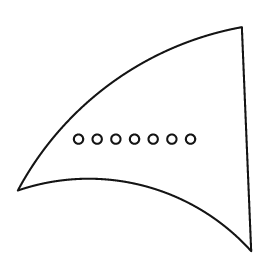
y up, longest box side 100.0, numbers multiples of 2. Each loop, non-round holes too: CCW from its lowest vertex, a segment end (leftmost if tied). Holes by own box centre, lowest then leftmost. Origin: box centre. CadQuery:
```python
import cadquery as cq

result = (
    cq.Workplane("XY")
    .moveTo(50.0, -48.0)
    .lineTo(46.0, 48.0)
    .threePointArc((-10.0, 24.0), (-50.0, -22.0))
    .threePointArc((4.0, -20.0), (50.0, -48.0))
    .close()
    .moveTo(-24.0, 0.0)
    .circle(2.0)
    .moveTo(-16.0, 0.0)
    .circle(2.0)
    .moveTo(-8.0, 0.0)
    .circle(2.0)
    .moveTo(0.0, 0.0)
    .circle(2.0)
    .moveTo(8.0, 0.0)
    .circle(2.0)
    .moveTo(16.0, 0.0)
    .circle(2.0)
    .moveTo(24.0, 0.0)
    .circle(2.0)
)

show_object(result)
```